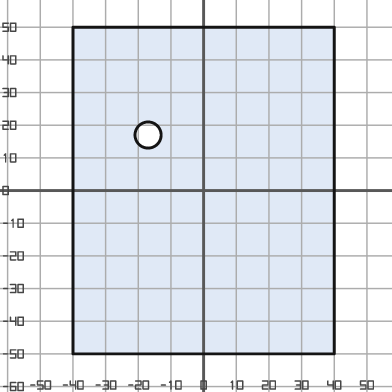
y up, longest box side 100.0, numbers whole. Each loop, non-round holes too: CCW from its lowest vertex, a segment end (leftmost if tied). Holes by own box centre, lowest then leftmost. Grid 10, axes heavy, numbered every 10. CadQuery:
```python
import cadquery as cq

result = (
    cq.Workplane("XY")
    .moveTo(-40.0, -50.0)
    .lineTo(40.0, -50.0)
    .lineTo(40.0, 50.0)
    .lineTo(-40.0, 50.0)
    .close()
    .moveTo(-17.0, 17.0)
    .circle(4.0)
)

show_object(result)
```